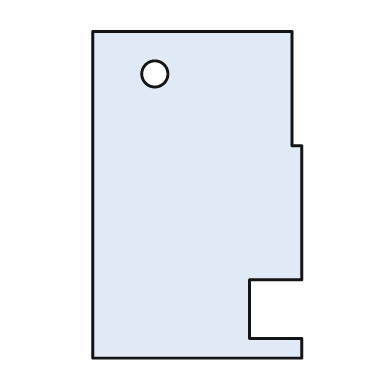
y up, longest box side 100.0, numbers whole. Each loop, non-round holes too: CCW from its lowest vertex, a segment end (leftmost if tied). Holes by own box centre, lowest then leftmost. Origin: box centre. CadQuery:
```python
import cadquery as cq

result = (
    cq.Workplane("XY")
    .moveTo(-32.0, -50.0)
    .lineTo(32.0, -50.0)
    .lineTo(32.0, -44.0)
    .lineTo(16.0, -44.0)
    .lineTo(16.0, -26.0)
    .lineTo(32.0, -26.0)
    .lineTo(32.0, 15.0)
    .lineTo(29.0, 15.0)
    .lineTo(29.0, 50.0)
    .lineTo(-32.0, 50.0)
    .close()
    .moveTo(-13.0, 37.0)
    .circle(4.0)
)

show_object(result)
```